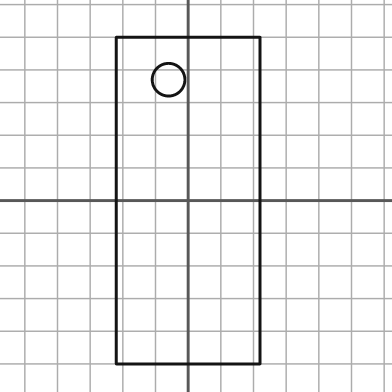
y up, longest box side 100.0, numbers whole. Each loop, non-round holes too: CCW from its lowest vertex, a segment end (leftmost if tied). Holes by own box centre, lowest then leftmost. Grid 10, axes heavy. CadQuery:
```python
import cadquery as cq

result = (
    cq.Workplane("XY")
    .moveTo(-22.0, -50.0)
    .lineTo(22.0, -50.0)
    .lineTo(22.0, 50.0)
    .lineTo(-22.0, 50.0)
    .close()
    .moveTo(-6.0, 37.0)
    .circle(5.0)
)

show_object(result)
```